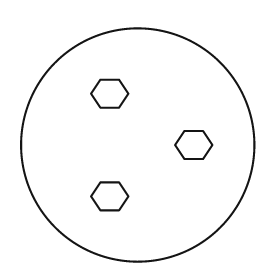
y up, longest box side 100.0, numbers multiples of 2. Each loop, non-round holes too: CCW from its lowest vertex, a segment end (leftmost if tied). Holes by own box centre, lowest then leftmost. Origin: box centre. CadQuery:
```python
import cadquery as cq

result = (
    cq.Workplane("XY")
    .moveTo(0.0, 0.0)
    .circle(50.0)
    .moveTo(-16.0, -28.0)
    .lineTo(-8.0, -28.0)
    .lineTo(-4.0, -22.0)
    .lineTo(-8.0, -16.0)
    .lineTo(-16.0, -16.0)
    .lineTo(-20.0, -22.0)
    .close()
    .moveTo(20.0, -6.0)
    .lineTo(28.0, -6.0)
    .lineTo(32.0, 0.0)
    .lineTo(28.0, 6.0)
    .lineTo(20.0, 6.0)
    .lineTo(16.0, 0.0)
    .close()
    .moveTo(-16.0, 16.0)
    .lineTo(-8.0, 16.0)
    .lineTo(-4.0, 22.0)
    .lineTo(-8.0, 28.0)
    .lineTo(-16.0, 28.0)
    .lineTo(-20.0, 22.0)
    .close()
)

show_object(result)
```